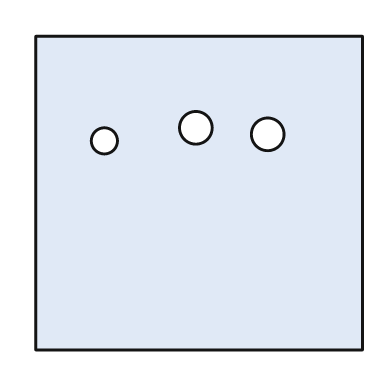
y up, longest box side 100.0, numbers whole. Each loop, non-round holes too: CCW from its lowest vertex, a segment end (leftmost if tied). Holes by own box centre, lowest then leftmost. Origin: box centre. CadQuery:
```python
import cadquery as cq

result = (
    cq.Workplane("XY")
    .moveTo(-50.0, -48.0)
    .lineTo(50.0, -48.0)
    .lineTo(50.0, 48.0)
    .lineTo(-50.0, 48.0)
    .close()
    .moveTo(-29.0, 16.0)
    .circle(4.0)
    .moveTo(21.0, 18.0)
    .circle(5.0)
    .moveTo(-1.0, 20.0)
    .circle(5.0)
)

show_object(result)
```